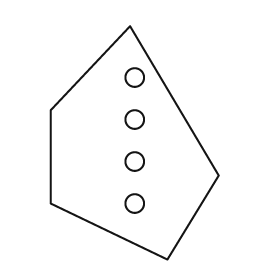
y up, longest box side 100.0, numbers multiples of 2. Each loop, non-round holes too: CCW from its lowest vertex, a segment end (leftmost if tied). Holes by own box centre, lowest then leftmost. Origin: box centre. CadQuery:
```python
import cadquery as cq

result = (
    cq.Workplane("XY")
    .moveTo(14.0, -50.0)
    .lineTo(36.0, -14.0)
    .lineTo(-2.0, 50.0)
    .lineTo(-36.0, 14.0)
    .lineTo(-36.0, -26.0)
    .close()
    .moveTo(0.0, -26.0)
    .circle(4.0)
    .moveTo(0.0, -8.0)
    .circle(4.0)
    .moveTo(0.0, 10.0)
    .circle(4.0)
    .moveTo(0.0, 28.0)
    .circle(4.0)
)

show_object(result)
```